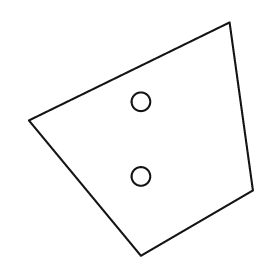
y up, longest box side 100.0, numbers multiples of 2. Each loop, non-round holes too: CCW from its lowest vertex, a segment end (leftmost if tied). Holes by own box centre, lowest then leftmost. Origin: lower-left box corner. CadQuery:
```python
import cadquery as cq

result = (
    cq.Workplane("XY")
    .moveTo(48.0, 0.0)
    .lineTo(96.0, 28.0)
    .lineTo(86.0, 100.0)
    .lineTo(0.0, 58.0)
    .close()
    .moveTo(48.0, 34.0)
    .circle(4.0)
    .moveTo(48.0, 66.0)
    .circle(4.0)
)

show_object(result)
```